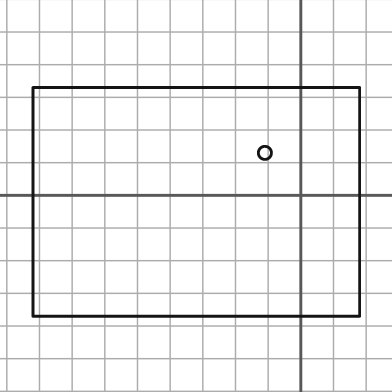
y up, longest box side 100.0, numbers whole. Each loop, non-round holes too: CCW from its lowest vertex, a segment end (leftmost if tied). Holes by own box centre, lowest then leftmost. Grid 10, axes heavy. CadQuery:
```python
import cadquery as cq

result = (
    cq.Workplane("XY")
    .moveTo(-82.0, -37.0)
    .lineTo(18.0, -37.0)
    .lineTo(18.0, 33.0)
    .lineTo(-82.0, 33.0)
    .close()
    .moveTo(-11.0, 13.0)
    .circle(2.0)
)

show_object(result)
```